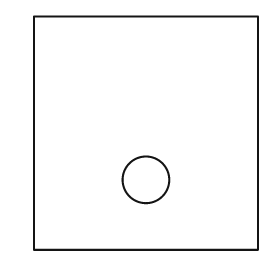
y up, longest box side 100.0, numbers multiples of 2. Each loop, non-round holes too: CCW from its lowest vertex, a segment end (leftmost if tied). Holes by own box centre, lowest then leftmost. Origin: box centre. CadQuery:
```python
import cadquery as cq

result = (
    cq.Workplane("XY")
    .moveTo(-48.0, -50.0)
    .lineTo(48.0, -50.0)
    .lineTo(48.0, 50.0)
    .lineTo(-48.0, 50.0)
    .close()
    .moveTo(0.0, -20.0)
    .circle(10.0)
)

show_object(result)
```